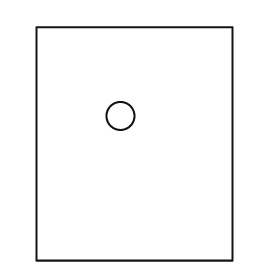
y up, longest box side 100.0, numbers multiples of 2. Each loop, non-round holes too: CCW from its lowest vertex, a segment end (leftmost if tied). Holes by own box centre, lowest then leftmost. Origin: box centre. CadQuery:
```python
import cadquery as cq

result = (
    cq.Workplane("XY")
    .moveTo(-42.0, -50.0)
    .lineTo(42.0, -50.0)
    .lineTo(42.0, 50.0)
    .lineTo(-42.0, 50.0)
    .close()
    .moveTo(-6.0, 12.0)
    .circle(6.0)
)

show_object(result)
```